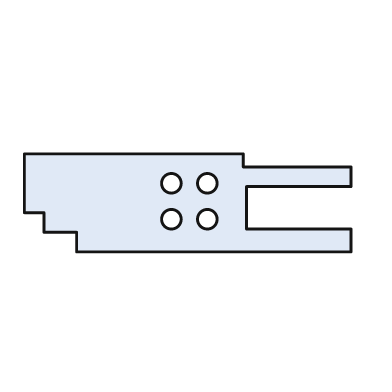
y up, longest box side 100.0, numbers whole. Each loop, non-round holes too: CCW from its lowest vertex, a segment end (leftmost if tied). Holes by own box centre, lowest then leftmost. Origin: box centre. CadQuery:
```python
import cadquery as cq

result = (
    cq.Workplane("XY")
    .moveTo(-34.0, -15.0)
    .lineTo(50.0, -15.0)
    .lineTo(50.0, -8.0)
    .lineTo(18.0, -8.0)
    .lineTo(18.0, 5.0)
    .lineTo(50.0, 5.0)
    .lineTo(50.0, 11.0)
    .lineTo(17.0, 11.0)
    .lineTo(17.0, 15.0)
    .lineTo(-50.0, 15.0)
    .lineTo(-50.0, -3.0)
    .lineTo(-44.0, -3.0)
    .lineTo(-44.0, -9.0)
    .lineTo(-34.0, -9.0)
    .close()
    .moveTo(-5.0, -5.0)
    .circle(3.0)
    .moveTo(6.0, -5.0)
    .circle(3.0)
    .moveTo(-5.0, 6.0)
    .circle(3.0)
    .moveTo(6.0, 6.0)
    .circle(3.0)
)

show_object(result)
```